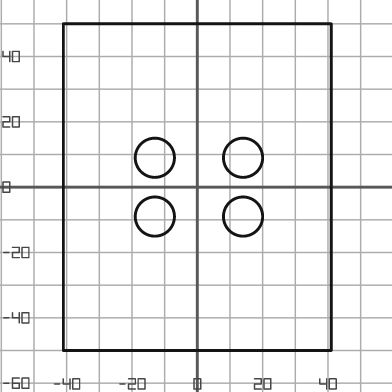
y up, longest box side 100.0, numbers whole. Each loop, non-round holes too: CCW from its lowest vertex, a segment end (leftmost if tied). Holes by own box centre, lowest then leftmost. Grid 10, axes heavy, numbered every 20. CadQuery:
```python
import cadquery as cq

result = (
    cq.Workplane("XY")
    .moveTo(-41.0, -50.0)
    .lineTo(41.0, -50.0)
    .lineTo(41.0, 50.0)
    .lineTo(-41.0, 50.0)
    .close()
    .moveTo(-13.0, -9.0)
    .circle(6.0)
    .moveTo(14.0, -9.0)
    .circle(6.0)
    .moveTo(-13.0, 9.0)
    .circle(6.0)
    .moveTo(14.0, 9.0)
    .circle(6.0)
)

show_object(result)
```